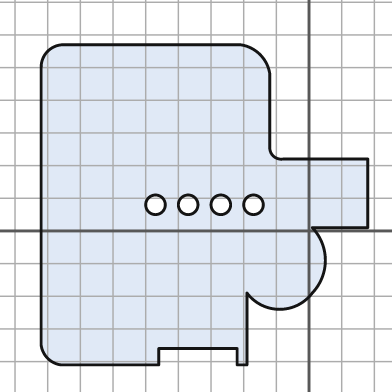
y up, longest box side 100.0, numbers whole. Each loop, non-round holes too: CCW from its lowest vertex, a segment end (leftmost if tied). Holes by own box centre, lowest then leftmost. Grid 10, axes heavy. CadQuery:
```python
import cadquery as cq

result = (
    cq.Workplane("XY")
    .moveTo(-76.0, -41.0)
    .lineTo(-46.0, -41.0)
    .lineTo(-46.0, -36.0)
    .lineTo(-22.0, -36.0)
    .lineTo(-22.0, -41.0)
    .lineTo(-19.0, -41.0)
    .lineTo(-19.0, -19.0)
    .threePointArc((-9.0, -24.0), (1.0, -19.0))
    .threePointArc((5.0, -9.0), (1.0, 1.0))
    .lineTo(18.0, 1.0)
    .lineTo(18.0, 22.0)
    .lineTo(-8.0, 22.0)
    .threePointArc((-11.0, 23.0), (-12.0, 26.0))
    .lineTo(-12.0, 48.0)
    .threePointArc((-15.0, 54.0), (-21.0, 57.0))
    .lineTo(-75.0, 57.0)
    .threePointArc((-80.0, 55.0), (-82.0, 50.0))
    .lineTo(-82.0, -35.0)
    .threePointArc((-80.0, -39.0), (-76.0, -41.0))
    .close()
    .moveTo(-47.0, 8.0)
    .circle(3.0)
    .moveTo(-37.0, 8.0)
    .circle(3.0)
    .moveTo(-27.0, 8.0)
    .circle(3.0)
    .moveTo(-17.0, 8.0)
    .circle(3.0)
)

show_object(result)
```